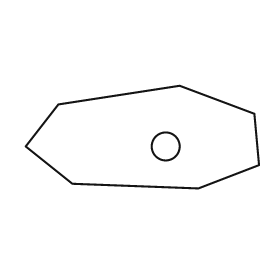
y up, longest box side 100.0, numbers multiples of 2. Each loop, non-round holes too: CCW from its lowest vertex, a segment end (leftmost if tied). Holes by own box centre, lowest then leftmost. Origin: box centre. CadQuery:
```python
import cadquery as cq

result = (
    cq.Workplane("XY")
    .moveTo(24.0, -22.0)
    .lineTo(50.0, -12.0)
    .lineTo(48.0, 10.0)
    .lineTo(16.0, 22.0)
    .lineTo(-36.0, 14.0)
    .lineTo(-50.0, -4.0)
    .lineTo(-30.0, -20.0)
    .close()
    .moveTo(10.0, -4.0)
    .circle(6.0)
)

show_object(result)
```